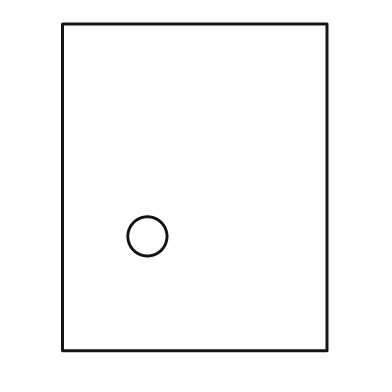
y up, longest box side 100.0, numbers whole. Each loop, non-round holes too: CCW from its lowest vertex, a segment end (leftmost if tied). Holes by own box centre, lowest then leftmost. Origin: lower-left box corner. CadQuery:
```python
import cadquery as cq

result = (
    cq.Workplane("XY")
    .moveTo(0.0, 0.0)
    .lineTo(81.0, 0.0)
    .lineTo(81.0, 100.0)
    .lineTo(0.0, 100.0)
    .close()
    .moveTo(26.0, 35.0)
    .circle(6.0)
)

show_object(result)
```